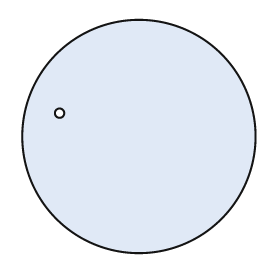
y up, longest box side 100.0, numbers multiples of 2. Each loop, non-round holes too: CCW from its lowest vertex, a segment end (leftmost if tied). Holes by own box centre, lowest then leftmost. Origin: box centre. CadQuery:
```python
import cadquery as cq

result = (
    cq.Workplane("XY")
    .moveTo(0.0, 0.0)
    .circle(50.0)
    .moveTo(-34.0, 10.0)
    .circle(2.0)
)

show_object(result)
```